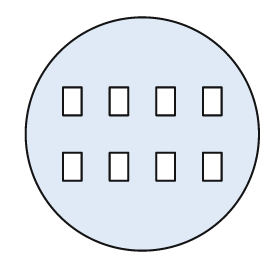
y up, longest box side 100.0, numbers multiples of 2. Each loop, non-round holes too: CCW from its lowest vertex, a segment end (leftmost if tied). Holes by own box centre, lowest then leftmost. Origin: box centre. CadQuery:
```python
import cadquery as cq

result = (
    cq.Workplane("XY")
    .moveTo(0.0, 0.0)
    .circle(50.0)
    .moveTo(-34.0, -20.0)
    .lineTo(-26.0, -20.0)
    .lineTo(-26.0, -8.0)
    .lineTo(-34.0, -8.0)
    .close()
    .moveTo(-14.0, -20.0)
    .lineTo(-6.0, -20.0)
    .lineTo(-6.0, -8.0)
    .lineTo(-14.0, -8.0)
    .close()
    .moveTo(6.0, -20.0)
    .lineTo(14.0, -20.0)
    .lineTo(14.0, -8.0)
    .lineTo(6.0, -8.0)
    .close()
    .moveTo(26.0, -20.0)
    .lineTo(34.0, -20.0)
    .lineTo(34.0, -8.0)
    .lineTo(26.0, -8.0)
    .close()
    .moveTo(-34.0, 8.0)
    .lineTo(-26.0, 8.0)
    .lineTo(-26.0, 20.0)
    .lineTo(-34.0, 20.0)
    .close()
    .moveTo(-14.0, 8.0)
    .lineTo(-6.0, 8.0)
    .lineTo(-6.0, 20.0)
    .lineTo(-14.0, 20.0)
    .close()
    .moveTo(6.0, 8.0)
    .lineTo(14.0, 8.0)
    .lineTo(14.0, 20.0)
    .lineTo(6.0, 20.0)
    .close()
    .moveTo(26.0, 8.0)
    .lineTo(34.0, 8.0)
    .lineTo(34.0, 20.0)
    .lineTo(26.0, 20.0)
    .close()
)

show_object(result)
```